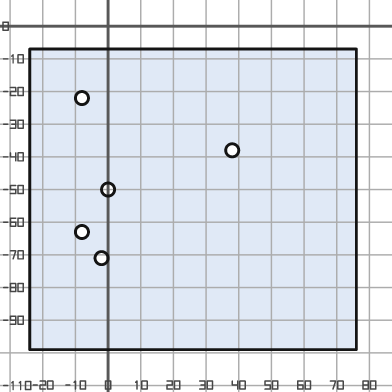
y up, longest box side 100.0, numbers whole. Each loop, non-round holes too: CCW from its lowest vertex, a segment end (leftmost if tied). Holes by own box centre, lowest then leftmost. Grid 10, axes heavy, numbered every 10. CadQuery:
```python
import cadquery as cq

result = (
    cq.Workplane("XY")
    .moveTo(-24.0, -99.0)
    .lineTo(76.0, -99.0)
    .lineTo(76.0, -7.0)
    .lineTo(-24.0, -7.0)
    .close()
    .moveTo(-2.0, -71.0)
    .circle(2.0)
    .moveTo(-8.0, -63.0)
    .circle(2.0)
    .moveTo(0.0, -50.0)
    .circle(2.0)
    .moveTo(38.0, -38.0)
    .circle(2.0)
    .moveTo(-8.0, -22.0)
    .circle(2.0)
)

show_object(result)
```